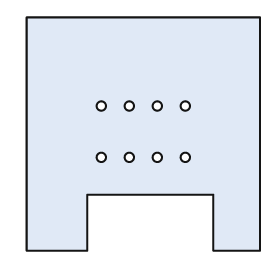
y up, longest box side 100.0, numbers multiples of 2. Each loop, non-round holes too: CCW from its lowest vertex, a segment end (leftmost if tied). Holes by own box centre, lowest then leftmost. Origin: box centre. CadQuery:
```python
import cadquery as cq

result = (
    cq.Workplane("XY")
    .moveTo(-50.0, -50.0)
    .lineTo(-24.0, -50.0)
    .lineTo(-24.0, -26.0)
    .lineTo(30.0, -26.0)
    .lineTo(30.0, -50.0)
    .lineTo(50.0, -50.0)
    .lineTo(50.0, 50.0)
    .lineTo(-50.0, 50.0)
    .close()
    .moveTo(-18.0, -10.0)
    .circle(2.0)
    .moveTo(-6.0, -10.0)
    .circle(2.0)
    .moveTo(6.0, -10.0)
    .circle(2.0)
    .moveTo(18.0, -10.0)
    .circle(2.0)
    .moveTo(-18.0, 12.0)
    .circle(2.0)
    .moveTo(-6.0, 12.0)
    .circle(2.0)
    .moveTo(6.0, 12.0)
    .circle(2.0)
    .moveTo(18.0, 12.0)
    .circle(2.0)
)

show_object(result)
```